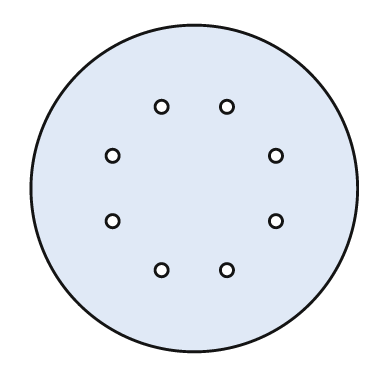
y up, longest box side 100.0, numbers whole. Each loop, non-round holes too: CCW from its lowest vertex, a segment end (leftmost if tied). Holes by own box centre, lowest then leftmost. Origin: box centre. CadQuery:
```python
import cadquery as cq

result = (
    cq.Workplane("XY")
    .moveTo(0.0, 0.0)
    .circle(50.0)
    .moveTo(-10.0, -25.0)
    .circle(2.0)
    .moveTo(10.0, -25.0)
    .circle(2.0)
    .moveTo(-25.0, -10.0)
    .circle(2.0)
    .moveTo(25.0, -10.0)
    .circle(2.0)
    .moveTo(-25.0, 10.0)
    .circle(2.0)
    .moveTo(25.0, 10.0)
    .circle(2.0)
    .moveTo(-10.0, 25.0)
    .circle(2.0)
    .moveTo(10.0, 25.0)
    .circle(2.0)
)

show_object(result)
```